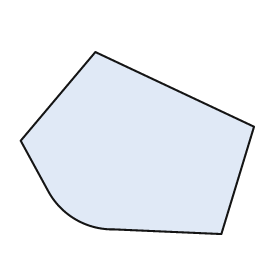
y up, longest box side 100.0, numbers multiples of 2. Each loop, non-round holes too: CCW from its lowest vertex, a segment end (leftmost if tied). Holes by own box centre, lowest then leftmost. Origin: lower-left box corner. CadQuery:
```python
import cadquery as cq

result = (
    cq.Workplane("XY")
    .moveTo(86.0, 0.0)
    .lineTo(100.0, 46.0)
    .lineTo(32.0, 78.0)
    .lineTo(0.0, 40.0)
    .lineTo(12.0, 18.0)
    .threePointArc((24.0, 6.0), (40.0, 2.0))
    .close()
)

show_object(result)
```